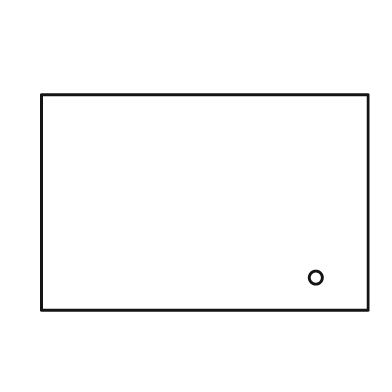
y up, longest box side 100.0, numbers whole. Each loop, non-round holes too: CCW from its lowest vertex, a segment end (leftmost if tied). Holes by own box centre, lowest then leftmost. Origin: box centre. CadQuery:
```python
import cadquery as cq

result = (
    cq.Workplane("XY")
    .moveTo(-50.0, -33.0)
    .lineTo(50.0, -33.0)
    .lineTo(50.0, 33.0)
    .lineTo(-50.0, 33.0)
    .close()
    .moveTo(34.0, -23.0)
    .circle(2.0)
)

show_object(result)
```